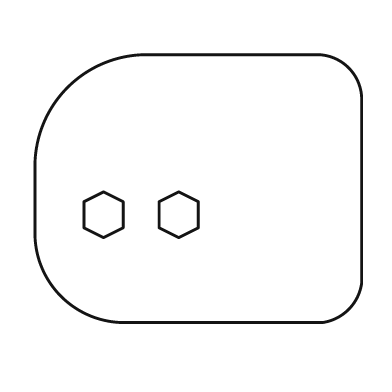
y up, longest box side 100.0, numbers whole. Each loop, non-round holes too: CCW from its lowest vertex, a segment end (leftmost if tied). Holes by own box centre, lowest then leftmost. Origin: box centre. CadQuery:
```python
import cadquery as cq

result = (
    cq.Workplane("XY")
    .moveTo(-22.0, -41.0)
    .lineTo(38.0, -41.0)
    .threePointArc((46.0, -37.0), (50.0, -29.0))
    .lineTo(50.0, 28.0)
    .threePointArc((46.0, 37.0), (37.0, 41.0))
    .lineTo(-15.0, 41.0)
    .threePointArc((-40.0, 31.0), (-50.0, 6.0))
    .lineTo(-50.0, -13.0)
    .threePointArc((-42.0, -33.0), (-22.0, -41.0))
    .close()
    .moveTo(-29.0, -15.0)
    .lineTo(-23.0, -12.0)
    .lineTo(-23.0, -4.0)
    .lineTo(-29.0, -1.0)
    .lineTo(-35.0, -4.0)
    .lineTo(-35.0, -12.0)
    .close()
    .moveTo(-6.0, -15.0)
    .lineTo(0.0, -12.0)
    .lineTo(0.0, -4.0)
    .lineTo(-6.0, -1.0)
    .lineTo(-12.0, -4.0)
    .lineTo(-12.0, -12.0)
    .close()
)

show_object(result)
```